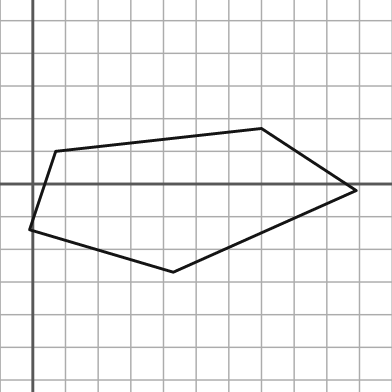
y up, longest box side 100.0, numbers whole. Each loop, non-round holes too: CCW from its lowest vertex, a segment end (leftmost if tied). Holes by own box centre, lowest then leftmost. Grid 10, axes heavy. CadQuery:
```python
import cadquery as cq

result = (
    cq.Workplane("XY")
    .moveTo(43.0, -27.0)
    .lineTo(99.0, -2.0)
    .lineTo(70.0, 17.0)
    .lineTo(7.0, 10.0)
    .lineTo(-1.0, -14.0)
    .close()
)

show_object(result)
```